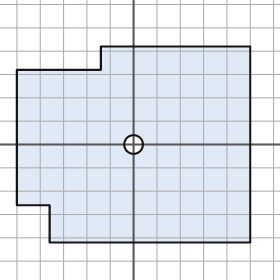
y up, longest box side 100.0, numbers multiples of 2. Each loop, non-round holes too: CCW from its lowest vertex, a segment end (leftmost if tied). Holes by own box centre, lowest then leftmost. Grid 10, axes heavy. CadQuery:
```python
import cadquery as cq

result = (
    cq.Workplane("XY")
    .moveTo(-36.0, -42.0)
    .lineTo(50.0, -42.0)
    .lineTo(50.0, 42.0)
    .lineTo(-14.0, 42.0)
    .lineTo(-14.0, 32.0)
    .lineTo(-50.0, 32.0)
    .lineTo(-50.0, -26.0)
    .lineTo(-36.0, -26.0)
    .close()
    .moveTo(0.0, 0.0)
    .circle(4.0)
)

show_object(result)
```